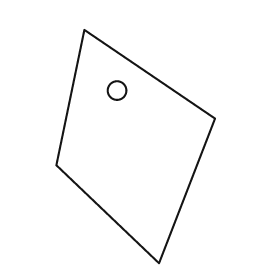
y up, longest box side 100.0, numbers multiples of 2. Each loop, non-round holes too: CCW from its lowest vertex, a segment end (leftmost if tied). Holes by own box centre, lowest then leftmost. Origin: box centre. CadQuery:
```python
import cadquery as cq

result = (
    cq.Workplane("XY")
    .moveTo(10.0, -50.0)
    .lineTo(34.0, 12.0)
    .lineTo(-22.0, 50.0)
    .lineTo(-34.0, -8.0)
    .close()
    .moveTo(-8.0, 24.0)
    .circle(4.0)
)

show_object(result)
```